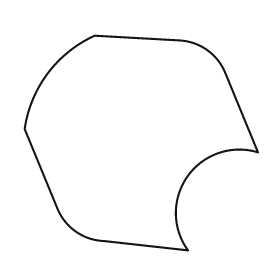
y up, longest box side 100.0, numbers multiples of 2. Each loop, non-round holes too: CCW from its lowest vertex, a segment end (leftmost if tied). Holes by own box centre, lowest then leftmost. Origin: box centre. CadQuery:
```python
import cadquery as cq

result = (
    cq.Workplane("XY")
    .moveTo(20.0, -46.0)
    .threePointArc((20.0, -14.0), (50.0, -4.0))
    .lineTo(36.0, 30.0)
    .threePointArc((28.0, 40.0), (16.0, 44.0))
    .lineTo(-20.0, 46.0)
    .threePointArc((-40.0, 30.0), (-50.0, 6.0))
    .lineTo(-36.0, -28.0)
    .threePointArc((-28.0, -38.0), (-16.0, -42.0))
    .close()
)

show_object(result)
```